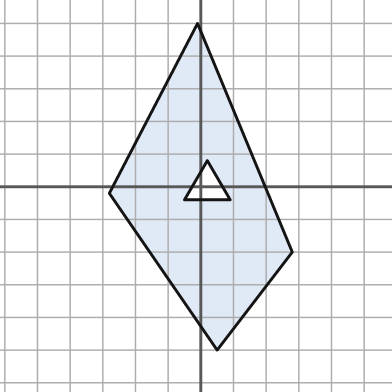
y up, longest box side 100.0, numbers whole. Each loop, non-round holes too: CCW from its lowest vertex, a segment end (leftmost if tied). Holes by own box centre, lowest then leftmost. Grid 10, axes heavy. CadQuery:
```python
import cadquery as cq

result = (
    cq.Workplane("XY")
    .moveTo(5.0, -50.0)
    .lineTo(28.0, -20.0)
    .lineTo(-1.0, 50.0)
    .lineTo(-28.0, -2.0)
    .close()
    .moveTo(-5.0, -4.0)
    .lineTo(9.0, -4.0)
    .lineTo(2.0, 8.0)
    .close()
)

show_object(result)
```